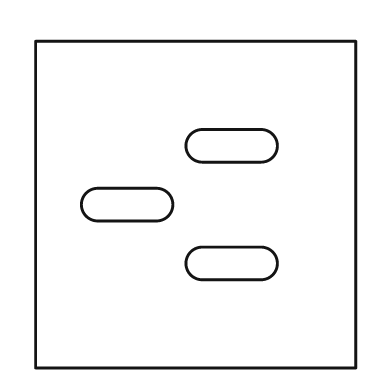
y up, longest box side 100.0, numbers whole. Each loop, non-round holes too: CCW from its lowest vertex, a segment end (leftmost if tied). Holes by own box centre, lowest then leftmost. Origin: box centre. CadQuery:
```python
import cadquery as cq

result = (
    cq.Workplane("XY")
    .moveTo(-49.0, -50.0)
    .lineTo(49.0, -50.0)
    .lineTo(49.0, 50.0)
    .lineTo(-49.0, 50.0)
    .close()
    .moveTo(2.0, -23.0)
    .lineTo(20.0, -23.0)
    .threePointArc((25.0, -18.0), (20.0, -13.0))
    .lineTo(2.0, -13.0)
    .threePointArc((-3.0, -18.0), (2.0, -23.0))
    .close()
    .moveTo(-30.0, -5.0)
    .lineTo(-12.0, -5.0)
    .threePointArc((-7.0, 0.0), (-12.0, 5.0))
    .lineTo(-30.0, 5.0)
    .threePointArc((-35.0, 0.0), (-30.0, -5.0))
    .close()
    .moveTo(2.0, 13.0)
    .lineTo(20.0, 13.0)
    .threePointArc((25.0, 18.0), (20.0, 23.0))
    .lineTo(2.0, 23.0)
    .threePointArc((-3.0, 18.0), (2.0, 13.0))
    .close()
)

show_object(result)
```